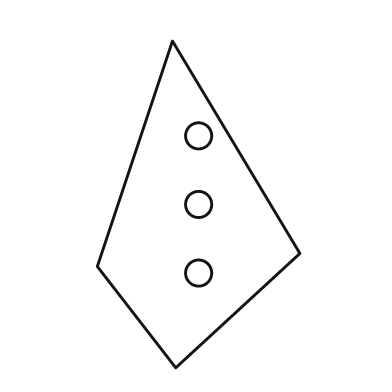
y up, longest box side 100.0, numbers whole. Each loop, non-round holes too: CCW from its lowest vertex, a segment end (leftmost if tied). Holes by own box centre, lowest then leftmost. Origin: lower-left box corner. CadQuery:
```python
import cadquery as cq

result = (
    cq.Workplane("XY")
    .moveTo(24.0, 0.0)
    .lineTo(62.0, 35.0)
    .lineTo(23.0, 100.0)
    .lineTo(0.0, 31.0)
    .close()
    .moveTo(31.0, 29.0)
    .circle(4.0)
    .moveTo(31.0, 50.0)
    .circle(4.0)
    .moveTo(31.0, 71.0)
    .circle(4.0)
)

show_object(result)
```